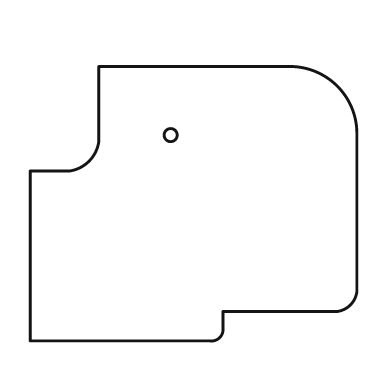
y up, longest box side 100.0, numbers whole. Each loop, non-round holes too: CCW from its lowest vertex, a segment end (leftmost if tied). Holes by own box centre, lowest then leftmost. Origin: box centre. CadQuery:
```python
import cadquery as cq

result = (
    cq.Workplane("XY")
    .moveTo(-50.0, -42.0)
    .lineTo(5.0, -42.0)
    .threePointArc((8.0, -41.0), (9.0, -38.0))
    .lineTo(9.0, -33.0)
    .lineTo(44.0, -33.0)
    .threePointArc((48.0, -31.0), (50.0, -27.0))
    .lineTo(50.0, 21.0)
    .threePointArc((44.0, 36.0), (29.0, 42.0))
    .lineTo(-29.0, 42.0)
    .lineTo(-29.0, 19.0)
    .threePointArc((-32.0, 13.0), (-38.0, 10.0))
    .lineTo(-50.0, 10.0)
    .close()
    .moveTo(-7.0, 21.0)
    .circle(2.0)
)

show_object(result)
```